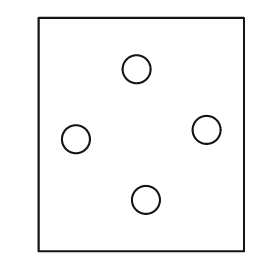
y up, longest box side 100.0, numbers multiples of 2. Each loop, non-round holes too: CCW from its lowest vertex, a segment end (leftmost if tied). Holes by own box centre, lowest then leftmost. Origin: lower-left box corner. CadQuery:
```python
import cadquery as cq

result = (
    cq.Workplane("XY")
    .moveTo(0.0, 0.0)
    .lineTo(88.0, 0.0)
    .lineTo(88.0, 100.0)
    .lineTo(0.0, 100.0)
    .close()
    .moveTo(46.0, 22.0)
    .circle(6.0)
    .moveTo(16.0, 48.0)
    .circle(6.0)
    .moveTo(72.0, 52.0)
    .circle(6.0)
    .moveTo(42.0, 78.0)
    .circle(6.0)
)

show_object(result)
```